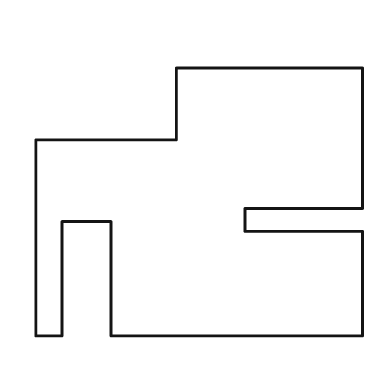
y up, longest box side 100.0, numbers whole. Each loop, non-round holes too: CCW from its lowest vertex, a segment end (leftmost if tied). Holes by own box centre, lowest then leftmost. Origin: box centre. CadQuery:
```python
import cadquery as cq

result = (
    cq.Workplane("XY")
    .moveTo(-50.0, -41.0)
    .lineTo(-42.0, -41.0)
    .lineTo(-42.0, -6.0)
    .lineTo(-27.0, -6.0)
    .lineTo(-27.0, -41.0)
    .lineTo(50.0, -41.0)
    .lineTo(50.0, -9.0)
    .lineTo(14.0, -9.0)
    .lineTo(14.0, -2.0)
    .lineTo(50.0, -2.0)
    .lineTo(50.0, 41.0)
    .lineTo(-7.0, 41.0)
    .lineTo(-7.0, 19.0)
    .lineTo(-50.0, 19.0)
    .close()
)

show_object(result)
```